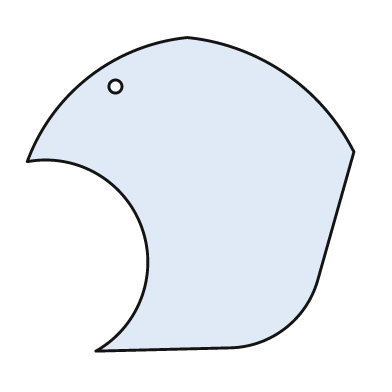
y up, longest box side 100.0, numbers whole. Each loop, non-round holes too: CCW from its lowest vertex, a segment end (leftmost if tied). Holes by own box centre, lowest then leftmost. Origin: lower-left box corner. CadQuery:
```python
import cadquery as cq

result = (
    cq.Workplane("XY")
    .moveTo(21.0, 0.0)
    .lineTo(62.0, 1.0)
    .threePointArc((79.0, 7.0), (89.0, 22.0))
    .lineTo(100.0, 61.0)
    .threePointArc((79.0, 85.0), (49.0, 96.0))
    .threePointArc((19.0, 84.0), (0.0, 58.0))
    .threePointArc((35.0, 38.0), (21.0, 0.0))
    .close()
    .moveTo(27.0, 81.0)
    .circle(2.0)
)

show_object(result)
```